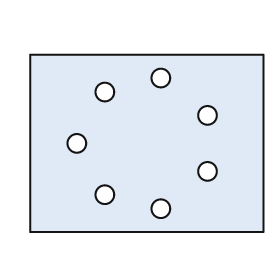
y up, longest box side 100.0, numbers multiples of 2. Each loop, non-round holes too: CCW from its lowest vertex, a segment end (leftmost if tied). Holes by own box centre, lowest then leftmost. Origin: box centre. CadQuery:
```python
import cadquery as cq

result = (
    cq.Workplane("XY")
    .moveTo(-50.0, -38.0)
    .lineTo(50.0, -38.0)
    .lineTo(50.0, 38.0)
    .lineTo(-50.0, 38.0)
    .close()
    .moveTo(6.0, -28.0)
    .circle(4.0)
    .moveTo(-18.0, -22.0)
    .circle(4.0)
    .moveTo(26.0, -12.0)
    .circle(4.0)
    .moveTo(-30.0, 0.0)
    .circle(4.0)
    .moveTo(26.0, 12.0)
    .circle(4.0)
    .moveTo(-18.0, 22.0)
    .circle(4.0)
    .moveTo(6.0, 28.0)
    .circle(4.0)
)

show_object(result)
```